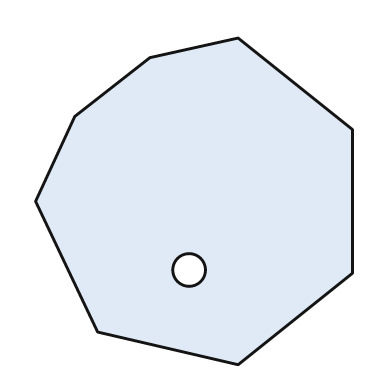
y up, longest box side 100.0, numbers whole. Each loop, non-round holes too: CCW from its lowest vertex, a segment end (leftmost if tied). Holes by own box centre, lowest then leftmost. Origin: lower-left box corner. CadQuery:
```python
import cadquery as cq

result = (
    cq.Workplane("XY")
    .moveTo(62.0, 0.0)
    .lineTo(97.0, 28.0)
    .lineTo(97.0, 72.0)
    .lineTo(62.0, 100.0)
    .lineTo(35.0, 94.0)
    .lineTo(12.0, 76.0)
    .lineTo(0.0, 50.0)
    .lineTo(19.0, 10.0)
    .close()
    .moveTo(47.0, 29.0)
    .circle(5.0)
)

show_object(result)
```